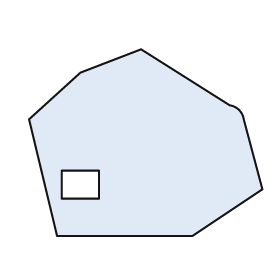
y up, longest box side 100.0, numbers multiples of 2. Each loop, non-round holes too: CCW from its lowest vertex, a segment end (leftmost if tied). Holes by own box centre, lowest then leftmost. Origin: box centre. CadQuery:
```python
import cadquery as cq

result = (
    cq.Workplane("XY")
    .moveTo(-38.0, -40.0)
    .lineTo(20.0, -40.0)
    .lineTo(50.0, -20.0)
    .lineTo(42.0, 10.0)
    .threePointArc((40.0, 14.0), (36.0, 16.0))
    .lineTo(-2.0, 40.0)
    .lineTo(-28.0, 30.0)
    .lineTo(-50.0, 10.0)
    .close()
    .moveTo(-36.0, -24.0)
    .lineTo(-20.0, -24.0)
    .lineTo(-20.0, -12.0)
    .lineTo(-36.0, -12.0)
    .close()
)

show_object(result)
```